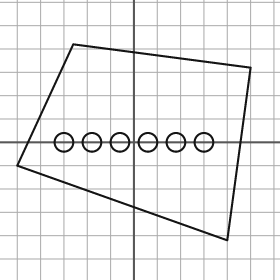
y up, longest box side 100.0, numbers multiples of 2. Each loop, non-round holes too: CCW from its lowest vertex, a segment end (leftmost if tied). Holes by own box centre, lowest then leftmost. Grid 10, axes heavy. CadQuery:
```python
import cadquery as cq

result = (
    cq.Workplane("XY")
    .moveTo(40.0, -42.0)
    .lineTo(50.0, 32.0)
    .lineTo(-26.0, 42.0)
    .lineTo(-50.0, -10.0)
    .close()
    .moveTo(-30.0, 0.0)
    .circle(4.0)
    .moveTo(-18.0, 0.0)
    .circle(4.0)
    .moveTo(-6.0, 0.0)
    .circle(4.0)
    .moveTo(6.0, 0.0)
    .circle(4.0)
    .moveTo(18.0, 0.0)
    .circle(4.0)
    .moveTo(30.0, 0.0)
    .circle(4.0)
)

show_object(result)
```